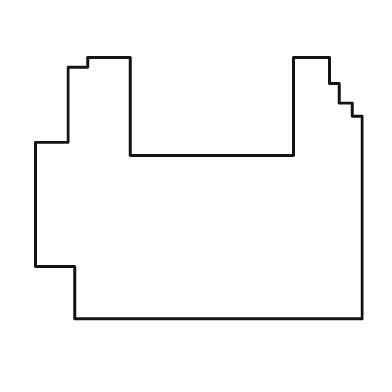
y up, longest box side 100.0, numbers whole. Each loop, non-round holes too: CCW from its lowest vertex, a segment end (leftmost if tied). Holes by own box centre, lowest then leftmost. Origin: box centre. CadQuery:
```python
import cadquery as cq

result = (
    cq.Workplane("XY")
    .moveTo(-38.0, -40.0)
    .lineTo(50.0, -40.0)
    .lineTo(50.0, 22.0)
    .lineTo(47.0, 22.0)
    .lineTo(47.0, 26.0)
    .lineTo(43.0, 26.0)
    .lineTo(43.0, 32.0)
    .lineTo(40.0, 32.0)
    .lineTo(40.0, 40.0)
    .lineTo(29.0, 40.0)
    .lineTo(29.0, 10.0)
    .lineTo(-21.0, 10.0)
    .lineTo(-21.0, 40.0)
    .lineTo(-34.0, 40.0)
    .lineTo(-34.0, 37.0)
    .lineTo(-40.0, 37.0)
    .lineTo(-40.0, 14.0)
    .lineTo(-50.0, 14.0)
    .lineTo(-50.0, -24.0)
    .lineTo(-38.0, -24.0)
    .close()
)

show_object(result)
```